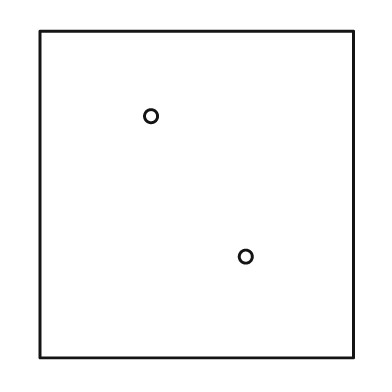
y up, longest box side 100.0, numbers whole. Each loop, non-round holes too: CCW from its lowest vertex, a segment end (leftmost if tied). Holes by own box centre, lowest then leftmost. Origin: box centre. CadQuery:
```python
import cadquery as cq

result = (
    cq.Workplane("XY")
    .moveTo(-48.0, -50.0)
    .lineTo(48.0, -50.0)
    .lineTo(48.0, 50.0)
    .lineTo(-48.0, 50.0)
    .close()
    .moveTo(15.0, -19.0)
    .circle(2.0)
    .moveTo(-14.0, 24.0)
    .circle(2.0)
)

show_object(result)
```